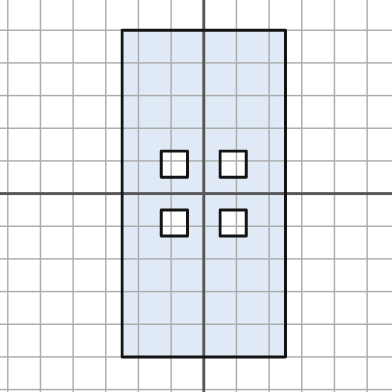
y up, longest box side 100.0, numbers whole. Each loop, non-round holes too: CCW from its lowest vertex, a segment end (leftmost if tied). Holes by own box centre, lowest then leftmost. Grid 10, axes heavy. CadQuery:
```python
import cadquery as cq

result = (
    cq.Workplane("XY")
    .moveTo(-25.0, -50.0)
    .lineTo(25.0, -50.0)
    .lineTo(25.0, 50.0)
    .lineTo(-25.0, 50.0)
    .close()
    .moveTo(-13.0, -13.0)
    .lineTo(-5.0, -13.0)
    .lineTo(-5.0, -5.0)
    .lineTo(-13.0, -5.0)
    .close()
    .moveTo(5.0, -13.0)
    .lineTo(13.0, -13.0)
    .lineTo(13.0, -5.0)
    .lineTo(5.0, -5.0)
    .close()
    .moveTo(-13.0, 5.0)
    .lineTo(-5.0, 5.0)
    .lineTo(-5.0, 13.0)
    .lineTo(-13.0, 13.0)
    .close()
    .moveTo(5.0, 5.0)
    .lineTo(13.0, 5.0)
    .lineTo(13.0, 13.0)
    .lineTo(5.0, 13.0)
    .close()
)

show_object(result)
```